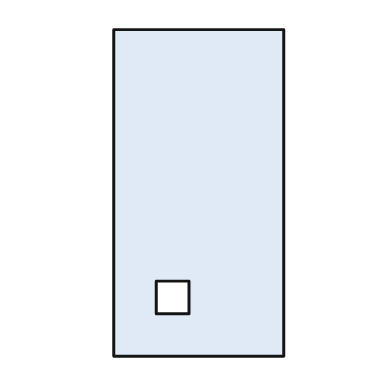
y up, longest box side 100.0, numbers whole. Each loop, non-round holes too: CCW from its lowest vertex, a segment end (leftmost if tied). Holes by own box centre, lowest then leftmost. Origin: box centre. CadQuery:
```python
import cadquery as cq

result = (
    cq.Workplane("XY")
    .moveTo(-26.0, -50.0)
    .lineTo(26.0, -50.0)
    .lineTo(26.0, 50.0)
    .lineTo(-26.0, 50.0)
    .close()
    .moveTo(-13.0, -37.0)
    .lineTo(-3.0, -37.0)
    .lineTo(-3.0, -27.0)
    .lineTo(-13.0, -27.0)
    .close()
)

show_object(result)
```